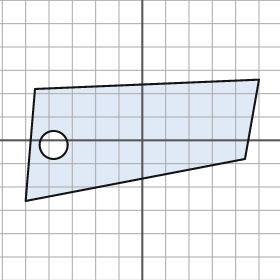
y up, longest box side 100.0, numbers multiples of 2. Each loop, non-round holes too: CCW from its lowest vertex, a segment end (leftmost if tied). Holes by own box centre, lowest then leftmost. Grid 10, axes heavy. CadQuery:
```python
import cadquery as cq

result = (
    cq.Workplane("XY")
    .moveTo(-50.0, -26.0)
    .lineTo(44.0, -8.0)
    .lineTo(50.0, 26.0)
    .lineTo(-46.0, 22.0)
    .close()
    .moveTo(-38.0, -2.0)
    .circle(6.0)
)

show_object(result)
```